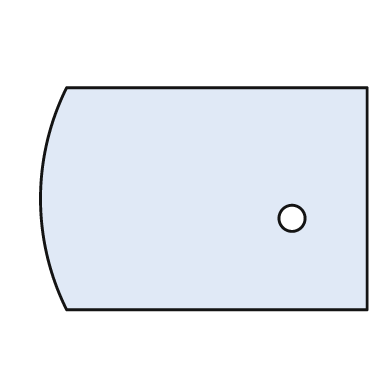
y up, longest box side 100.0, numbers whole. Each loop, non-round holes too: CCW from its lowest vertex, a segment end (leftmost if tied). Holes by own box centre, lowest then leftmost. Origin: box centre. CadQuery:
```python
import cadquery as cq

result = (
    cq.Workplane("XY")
    .moveTo(-42.0, -34.0)
    .lineTo(50.0, -34.0)
    .lineTo(50.0, 34.0)
    .lineTo(-42.0, 34.0)
    .threePointArc((-50.0, 0.0), (-42.0, -34.0))
    .close()
    .moveTo(27.0, -6.0)
    .circle(4.0)
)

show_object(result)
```